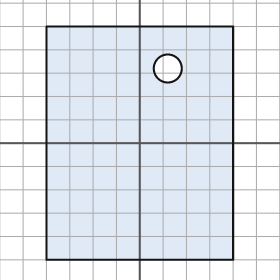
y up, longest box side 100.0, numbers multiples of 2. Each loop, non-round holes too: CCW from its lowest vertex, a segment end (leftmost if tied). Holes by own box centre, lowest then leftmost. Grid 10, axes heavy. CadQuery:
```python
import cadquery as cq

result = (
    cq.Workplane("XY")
    .moveTo(-40.0, -50.0)
    .lineTo(40.0, -50.0)
    .lineTo(40.0, 50.0)
    .lineTo(-40.0, 50.0)
    .close()
    .moveTo(12.0, 32.0)
    .circle(6.0)
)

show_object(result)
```